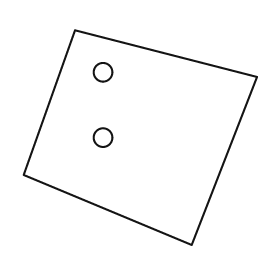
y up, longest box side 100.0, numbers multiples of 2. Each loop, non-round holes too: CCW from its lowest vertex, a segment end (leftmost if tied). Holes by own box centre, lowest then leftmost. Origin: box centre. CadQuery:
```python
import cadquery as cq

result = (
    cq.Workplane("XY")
    .moveTo(22.0, -46.0)
    .lineTo(50.0, 26.0)
    .lineTo(-28.0, 46.0)
    .lineTo(-50.0, -16.0)
    .close()
    .moveTo(-16.0, 0.0)
    .circle(4.0)
    .moveTo(-16.0, 28.0)
    .circle(4.0)
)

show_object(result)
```